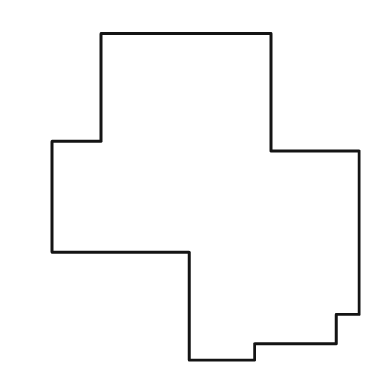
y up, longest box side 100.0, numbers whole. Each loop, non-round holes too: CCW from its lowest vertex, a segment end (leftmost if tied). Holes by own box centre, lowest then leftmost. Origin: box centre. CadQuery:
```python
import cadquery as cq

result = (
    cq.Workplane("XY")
    .moveTo(-5.0, -50.0)
    .lineTo(15.0, -50.0)
    .lineTo(15.0, -45.0)
    .lineTo(40.0, -45.0)
    .lineTo(40.0, -36.0)
    .lineTo(47.0, -36.0)
    .lineTo(47.0, 14.0)
    .lineTo(20.0, 14.0)
    .lineTo(20.0, 50.0)
    .lineTo(-32.0, 50.0)
    .lineTo(-32.0, 17.0)
    .lineTo(-47.0, 17.0)
    .lineTo(-47.0, -17.0)
    .lineTo(-5.0, -17.0)
    .close()
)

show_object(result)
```